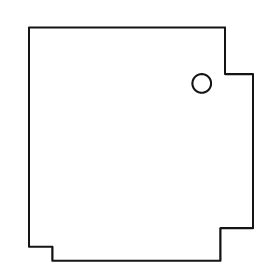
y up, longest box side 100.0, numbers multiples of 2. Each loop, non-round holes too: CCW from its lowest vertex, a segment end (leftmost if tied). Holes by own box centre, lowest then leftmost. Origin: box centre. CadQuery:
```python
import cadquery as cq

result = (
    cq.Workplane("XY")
    .moveTo(-38.0, -50.0)
    .lineTo(34.0, -50.0)
    .lineTo(34.0, -36.0)
    .lineTo(48.0, -36.0)
    .lineTo(48.0, 30.0)
    .lineTo(36.0, 30.0)
    .lineTo(36.0, 50.0)
    .lineTo(-48.0, 50.0)
    .lineTo(-48.0, -44.0)
    .lineTo(-38.0, -44.0)
    .close()
    .moveTo(26.0, 26.0)
    .circle(4.0)
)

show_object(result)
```